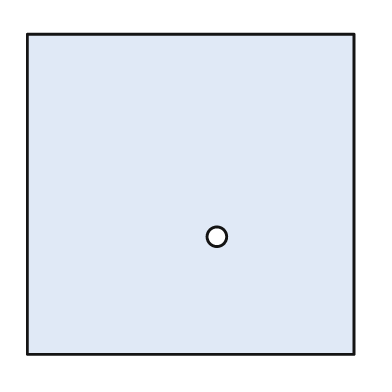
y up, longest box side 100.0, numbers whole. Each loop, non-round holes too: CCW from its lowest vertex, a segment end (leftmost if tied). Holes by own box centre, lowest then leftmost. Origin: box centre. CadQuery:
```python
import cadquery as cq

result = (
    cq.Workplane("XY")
    .moveTo(-50.0, -49.0)
    .lineTo(50.0, -49.0)
    .lineTo(50.0, 49.0)
    .lineTo(-50.0, 49.0)
    .close()
    .moveTo(8.0, -13.0)
    .circle(3.0)
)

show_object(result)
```